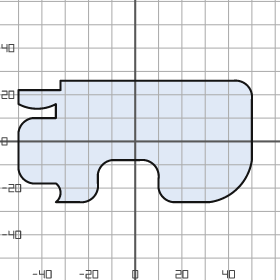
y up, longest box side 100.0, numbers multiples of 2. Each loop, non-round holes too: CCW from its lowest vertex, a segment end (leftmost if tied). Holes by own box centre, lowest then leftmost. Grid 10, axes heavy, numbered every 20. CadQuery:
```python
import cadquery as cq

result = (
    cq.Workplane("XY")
    .moveTo(-34.0, -26.0)
    .lineTo(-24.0, -26.0)
    .threePointArc((-18.0, -24.0), (-16.0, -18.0))
    .lineTo(-16.0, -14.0)
    .threePointArc((-14.0, -10.0), (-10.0, -8.0))
    .lineTo(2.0, -8.0)
    .threePointArc((8.0, -10.0), (10.0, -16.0))
    .lineTo(10.0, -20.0)
    .threePointArc((12.0, -24.0), (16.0, -26.0))
    .lineTo(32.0, -26.0)
    .threePointArc((44.0, -20.0), (50.0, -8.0))
    .lineTo(50.0, 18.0)
    .threePointArc((48.0, 24.0), (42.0, 26.0))
    .lineTo(-32.0, 26.0)
    .lineTo(-32.0, 22.0)
    .lineTo(-50.0, 22.0)
    .lineTo(-50.0, 16.0)
    .threePointArc((-42.0, 14.0), (-34.0, 16.0))
    .lineTo(-34.0, 10.0)
    .lineTo(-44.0, 10.0)
    .threePointArc((-48.0, 8.0), (-50.0, 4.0))
    .lineTo(-50.0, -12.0)
    .threePointArc((-48.0, -16.0), (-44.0, -18.0))
    .lineTo(-34.0, -18.0)
    .threePointArc((-32.0, -22.0), (-34.0, -26.0))
    .close()
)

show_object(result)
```